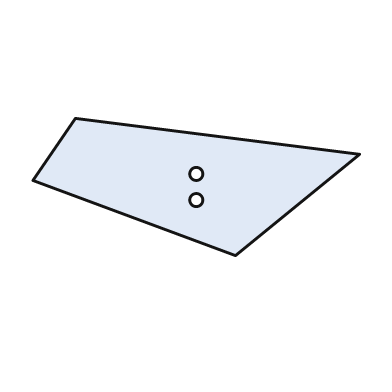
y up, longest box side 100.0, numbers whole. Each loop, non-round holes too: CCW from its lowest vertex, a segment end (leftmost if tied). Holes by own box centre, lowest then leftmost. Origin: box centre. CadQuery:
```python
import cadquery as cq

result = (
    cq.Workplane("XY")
    .moveTo(12.0, -21.0)
    .lineTo(50.0, 10.0)
    .lineTo(-37.0, 21.0)
    .lineTo(-50.0, 2.0)
    .close()
    .moveTo(0.0, -4.0)
    .circle(2.0)
    .moveTo(0.0, 4.0)
    .circle(2.0)
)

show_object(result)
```